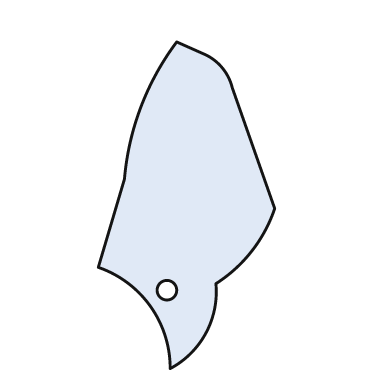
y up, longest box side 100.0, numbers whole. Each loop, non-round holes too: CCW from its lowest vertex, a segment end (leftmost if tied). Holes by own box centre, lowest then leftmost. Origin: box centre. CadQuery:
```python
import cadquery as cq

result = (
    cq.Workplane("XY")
    .moveTo(-5.0, -50.0)
    .threePointArc((6.0, -39.0), (9.0, -24.0))
    .threePointArc((20.0, -14.0), (27.0, -1.0))
    .lineTo(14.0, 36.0)
    .threePointArc((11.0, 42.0), (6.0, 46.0))
    .lineTo(-3.0, 50.0)
    .threePointArc((-14.0, 30.0), (-19.0, 8.0))
    .lineTo(-27.0, -19.0)
    .threePointArc((-11.0, -31.0), (-5.0, -50.0))
    .close()
    .moveTo(-6.0, -26.0)
    .circle(3.0)
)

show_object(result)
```